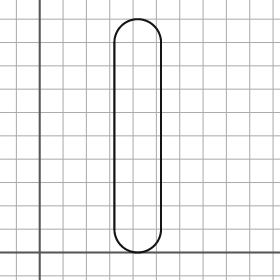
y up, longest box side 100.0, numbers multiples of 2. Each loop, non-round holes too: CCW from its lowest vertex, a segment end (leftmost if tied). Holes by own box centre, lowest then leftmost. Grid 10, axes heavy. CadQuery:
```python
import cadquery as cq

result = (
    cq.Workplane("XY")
    .moveTo(32.0, 10.0)
    .threePointArc((42.0, 0.0), (52.0, 10.0))
    .lineTo(52.0, 90.0)
    .threePointArc((42.0, 100.0), (32.0, 90.0))
    .close()
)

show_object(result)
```